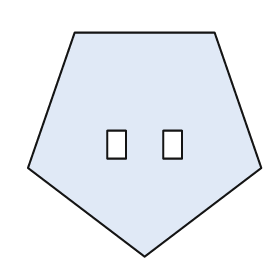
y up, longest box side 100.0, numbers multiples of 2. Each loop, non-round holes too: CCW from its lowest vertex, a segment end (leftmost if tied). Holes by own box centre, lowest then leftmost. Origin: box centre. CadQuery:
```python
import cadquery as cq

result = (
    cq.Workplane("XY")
    .moveTo(0.0, -48.0)
    .lineTo(50.0, -10.0)
    .lineTo(30.0, 48.0)
    .lineTo(-30.0, 48.0)
    .lineTo(-50.0, -10.0)
    .close()
    .moveTo(-16.0, -6.0)
    .lineTo(-8.0, -6.0)
    .lineTo(-8.0, 6.0)
    .lineTo(-16.0, 6.0)
    .close()
    .moveTo(8.0, -6.0)
    .lineTo(16.0, -6.0)
    .lineTo(16.0, 6.0)
    .lineTo(8.0, 6.0)
    .close()
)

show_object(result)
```